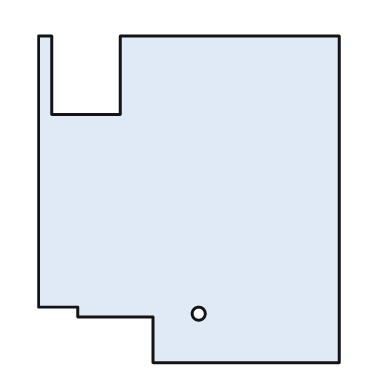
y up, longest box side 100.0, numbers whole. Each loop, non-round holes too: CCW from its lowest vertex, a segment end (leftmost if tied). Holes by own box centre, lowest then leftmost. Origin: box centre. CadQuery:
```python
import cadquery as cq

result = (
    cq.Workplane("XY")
    .moveTo(-11.0, -50.0)
    .lineTo(46.0, -50.0)
    .lineTo(46.0, 50.0)
    .lineTo(-21.0, 50.0)
    .lineTo(-21.0, 26.0)
    .lineTo(-42.0, 26.0)
    .lineTo(-42.0, 50.0)
    .lineTo(-46.0, 50.0)
    .lineTo(-46.0, -33.0)
    .lineTo(-34.0, -33.0)
    .lineTo(-34.0, -36.0)
    .lineTo(-11.0, -36.0)
    .close()
    .moveTo(3.0, -35.0)
    .circle(2.0)
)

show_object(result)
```